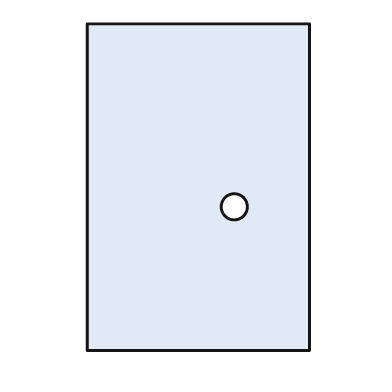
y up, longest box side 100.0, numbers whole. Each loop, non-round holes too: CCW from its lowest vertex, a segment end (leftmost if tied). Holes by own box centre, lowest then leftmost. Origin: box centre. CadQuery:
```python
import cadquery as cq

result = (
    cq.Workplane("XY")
    .moveTo(-34.0, -50.0)
    .lineTo(34.0, -50.0)
    .lineTo(34.0, 50.0)
    .lineTo(-34.0, 50.0)
    .close()
    .moveTo(11.0, -6.0)
    .circle(4.0)
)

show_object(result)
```